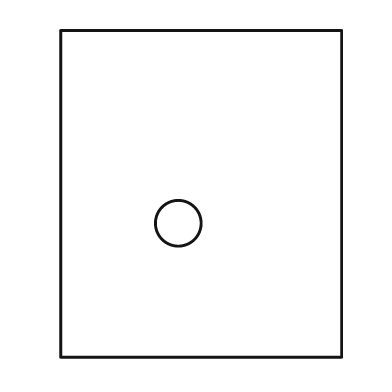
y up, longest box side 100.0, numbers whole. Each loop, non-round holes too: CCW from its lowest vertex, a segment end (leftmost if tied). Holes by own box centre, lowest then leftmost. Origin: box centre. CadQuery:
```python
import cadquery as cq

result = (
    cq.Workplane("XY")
    .moveTo(-43.0, -50.0)
    .lineTo(43.0, -50.0)
    .lineTo(43.0, 50.0)
    .lineTo(-43.0, 50.0)
    .close()
    .moveTo(-7.0, -9.0)
    .circle(7.0)
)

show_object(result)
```